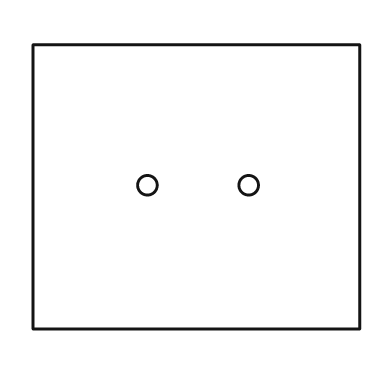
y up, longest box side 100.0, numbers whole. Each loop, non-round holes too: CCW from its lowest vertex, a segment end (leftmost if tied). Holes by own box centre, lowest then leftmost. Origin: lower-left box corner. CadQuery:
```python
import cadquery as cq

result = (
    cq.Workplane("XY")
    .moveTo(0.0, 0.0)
    .lineTo(100.0, 0.0)
    .lineTo(100.0, 87.0)
    .lineTo(0.0, 87.0)
    .close()
    .moveTo(35.0, 44.0)
    .circle(3.0)
    .moveTo(66.0, 44.0)
    .circle(3.0)
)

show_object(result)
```